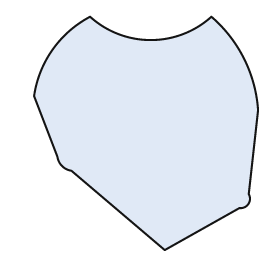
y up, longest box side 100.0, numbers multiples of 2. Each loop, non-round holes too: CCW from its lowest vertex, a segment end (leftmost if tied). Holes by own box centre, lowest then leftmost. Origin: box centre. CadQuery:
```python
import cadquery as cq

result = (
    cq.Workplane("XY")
    .moveTo(8.0, -50.0)
    .lineTo(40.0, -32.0)
    .threePointArc((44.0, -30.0), (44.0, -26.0))
    .lineTo(48.0, 10.0)
    .threePointArc((42.0, 32.0), (28.0, 50.0))
    .threePointArc((2.0, 40.0), (-24.0, 50.0))
    .threePointArc((-40.0, 36.0), (-48.0, 16.0))
    .lineTo(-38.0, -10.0)
    .threePointArc((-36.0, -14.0), (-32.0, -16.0))
    .close()
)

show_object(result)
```